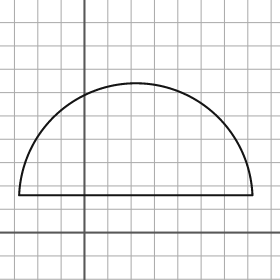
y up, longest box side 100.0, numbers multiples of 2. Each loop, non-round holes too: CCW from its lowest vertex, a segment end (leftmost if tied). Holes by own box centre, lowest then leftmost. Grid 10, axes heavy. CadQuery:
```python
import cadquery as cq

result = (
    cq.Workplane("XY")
    .moveTo(-28.0, 16.0)
    .lineTo(72.0, 16.0)
    .threePointArc((22.0, 64.0), (-28.0, 16.0))
    .close()
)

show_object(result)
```